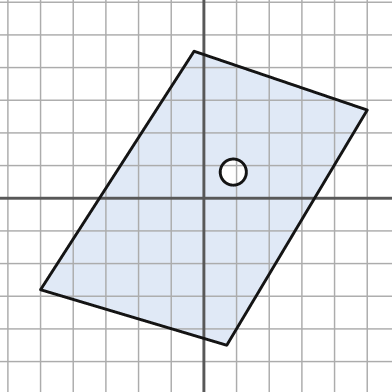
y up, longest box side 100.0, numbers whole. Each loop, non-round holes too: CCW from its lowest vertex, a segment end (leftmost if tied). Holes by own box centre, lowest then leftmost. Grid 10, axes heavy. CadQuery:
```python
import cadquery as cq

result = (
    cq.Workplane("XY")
    .moveTo(7.0, -45.0)
    .lineTo(50.0, 27.0)
    .lineTo(-3.0, 45.0)
    .lineTo(-50.0, -28.0)
    .close()
    .moveTo(9.0, 8.0)
    .circle(4.0)
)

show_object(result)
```